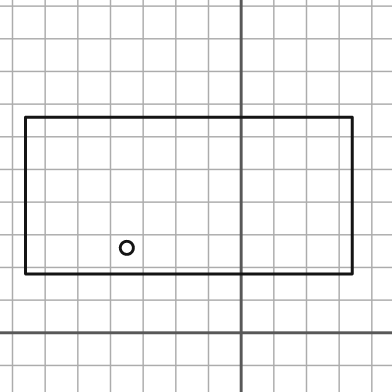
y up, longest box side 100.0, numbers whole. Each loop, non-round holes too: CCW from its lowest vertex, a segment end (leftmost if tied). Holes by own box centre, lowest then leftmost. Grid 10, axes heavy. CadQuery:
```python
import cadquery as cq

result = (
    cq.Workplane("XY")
    .moveTo(-66.0, 18.0)
    .lineTo(34.0, 18.0)
    .lineTo(34.0, 66.0)
    .lineTo(-66.0, 66.0)
    .close()
    .moveTo(-35.0, 26.0)
    .circle(2.0)
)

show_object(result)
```